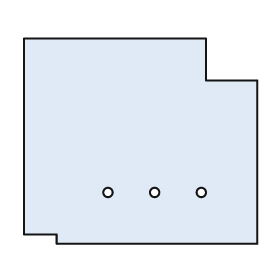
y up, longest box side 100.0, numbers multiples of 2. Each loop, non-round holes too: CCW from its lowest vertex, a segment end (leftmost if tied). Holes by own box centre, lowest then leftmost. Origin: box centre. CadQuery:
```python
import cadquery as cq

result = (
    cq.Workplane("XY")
    .moveTo(-36.0, -44.0)
    .lineTo(50.0, -44.0)
    .lineTo(50.0, 26.0)
    .lineTo(28.0, 26.0)
    .lineTo(28.0, 44.0)
    .lineTo(-50.0, 44.0)
    .lineTo(-50.0, -40.0)
    .lineTo(-36.0, -40.0)
    .close()
    .moveTo(-14.0, -22.0)
    .circle(2.0)
    .moveTo(6.0, -22.0)
    .circle(2.0)
    .moveTo(26.0, -22.0)
    .circle(2.0)
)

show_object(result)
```